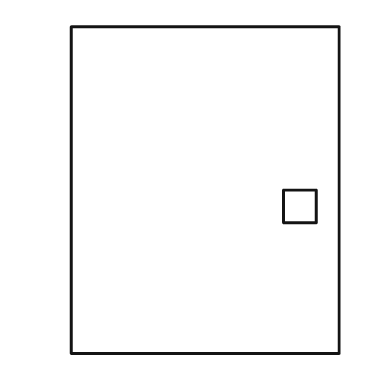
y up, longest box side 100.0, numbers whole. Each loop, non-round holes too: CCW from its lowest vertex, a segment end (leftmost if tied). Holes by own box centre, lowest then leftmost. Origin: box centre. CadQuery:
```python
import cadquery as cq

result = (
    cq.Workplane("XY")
    .moveTo(-41.0, -50.0)
    .lineTo(41.0, -50.0)
    .lineTo(41.0, 50.0)
    .lineTo(-41.0, 50.0)
    .close()
    .moveTo(24.0, -10.0)
    .lineTo(34.0, -10.0)
    .lineTo(34.0, 0.0)
    .lineTo(24.0, 0.0)
    .close()
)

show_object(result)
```